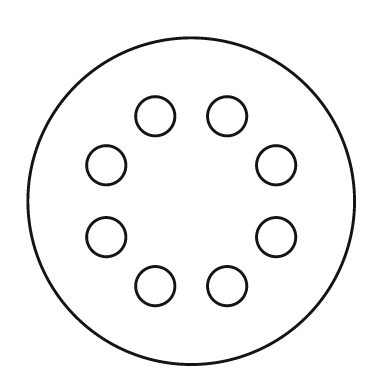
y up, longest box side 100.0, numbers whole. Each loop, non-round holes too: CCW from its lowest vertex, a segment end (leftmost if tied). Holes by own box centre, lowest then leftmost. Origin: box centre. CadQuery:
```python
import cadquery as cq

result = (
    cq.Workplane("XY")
    .moveTo(0.0, 0.0)
    .circle(50.0)
    .moveTo(-11.0, -26.0)
    .circle(6.0)
    .moveTo(11.0, -26.0)
    .circle(6.0)
    .moveTo(-26.0, -11.0)
    .circle(6.0)
    .moveTo(26.0, -11.0)
    .circle(6.0)
    .moveTo(-26.0, 11.0)
    .circle(6.0)
    .moveTo(26.0, 11.0)
    .circle(6.0)
    .moveTo(-11.0, 26.0)
    .circle(6.0)
    .moveTo(11.0, 26.0)
    .circle(6.0)
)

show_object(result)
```